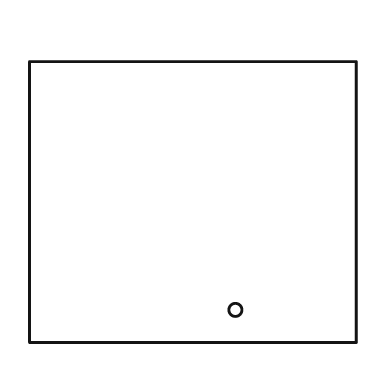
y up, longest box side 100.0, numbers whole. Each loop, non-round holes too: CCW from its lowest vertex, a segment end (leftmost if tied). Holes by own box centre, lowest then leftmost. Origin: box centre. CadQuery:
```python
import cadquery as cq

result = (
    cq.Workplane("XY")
    .moveTo(-50.0, -43.0)
    .lineTo(50.0, -43.0)
    .lineTo(50.0, 43.0)
    .lineTo(-50.0, 43.0)
    .close()
    .moveTo(13.0, -33.0)
    .circle(2.0)
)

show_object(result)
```